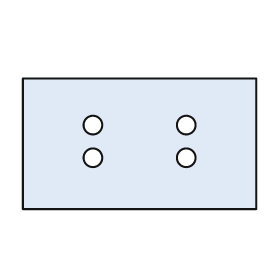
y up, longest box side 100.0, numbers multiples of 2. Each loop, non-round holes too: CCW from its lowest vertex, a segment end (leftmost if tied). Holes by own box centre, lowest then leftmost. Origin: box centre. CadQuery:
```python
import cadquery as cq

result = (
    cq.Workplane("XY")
    .moveTo(-50.0, -28.0)
    .lineTo(50.0, -28.0)
    .lineTo(50.0, 28.0)
    .lineTo(-50.0, 28.0)
    .close()
    .moveTo(-20.0, -6.0)
    .circle(4.0)
    .moveTo(20.0, -6.0)
    .circle(4.0)
    .moveTo(-20.0, 8.0)
    .circle(4.0)
    .moveTo(20.0, 8.0)
    .circle(4.0)
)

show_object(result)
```